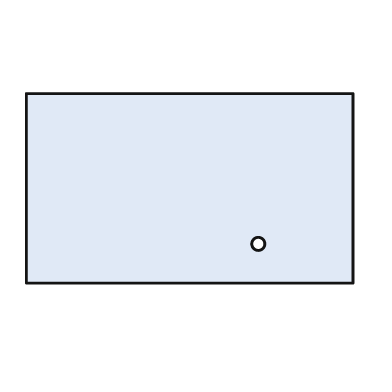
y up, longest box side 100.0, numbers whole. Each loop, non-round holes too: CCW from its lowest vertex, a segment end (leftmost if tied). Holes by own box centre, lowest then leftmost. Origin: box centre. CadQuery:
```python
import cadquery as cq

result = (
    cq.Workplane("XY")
    .moveTo(-50.0, -29.0)
    .lineTo(50.0, -29.0)
    .lineTo(50.0, 29.0)
    .lineTo(-50.0, 29.0)
    .close()
    .moveTo(21.0, -17.0)
    .circle(2.0)
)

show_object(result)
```